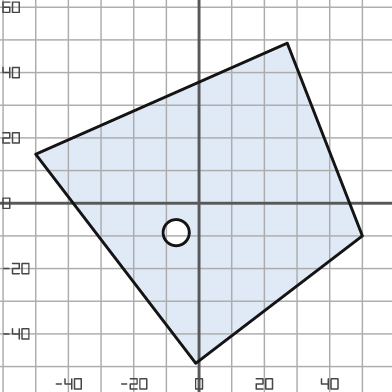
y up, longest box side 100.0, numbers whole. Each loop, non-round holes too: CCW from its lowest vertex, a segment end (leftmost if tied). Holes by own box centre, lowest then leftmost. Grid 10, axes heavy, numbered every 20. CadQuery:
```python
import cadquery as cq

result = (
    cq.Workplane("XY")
    .moveTo(-1.0, -49.0)
    .lineTo(50.0, -10.0)
    .lineTo(27.0, 49.0)
    .lineTo(-50.0, 15.0)
    .close()
    .moveTo(-7.0, -9.0)
    .circle(4.0)
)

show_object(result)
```